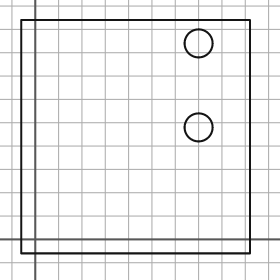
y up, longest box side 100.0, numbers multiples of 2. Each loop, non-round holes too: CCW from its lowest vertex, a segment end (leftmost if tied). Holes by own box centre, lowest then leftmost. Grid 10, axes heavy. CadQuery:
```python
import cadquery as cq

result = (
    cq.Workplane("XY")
    .moveTo(-6.0, -6.0)
    .lineTo(92.0, -6.0)
    .lineTo(92.0, 94.0)
    .lineTo(-6.0, 94.0)
    .close()
    .moveTo(70.0, 48.0)
    .circle(6.0)
    .moveTo(70.0, 84.0)
    .circle(6.0)
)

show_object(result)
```